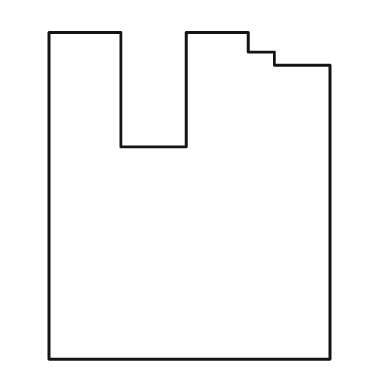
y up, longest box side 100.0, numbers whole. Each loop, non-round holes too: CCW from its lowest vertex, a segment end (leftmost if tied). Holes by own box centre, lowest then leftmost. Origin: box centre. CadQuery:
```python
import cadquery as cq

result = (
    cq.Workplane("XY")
    .moveTo(-43.0, -50.0)
    .lineTo(43.0, -50.0)
    .lineTo(43.0, 40.0)
    .lineTo(26.0, 40.0)
    .lineTo(26.0, 44.0)
    .lineTo(18.0, 44.0)
    .lineTo(18.0, 50.0)
    .lineTo(-1.0, 50.0)
    .lineTo(-1.0, 15.0)
    .lineTo(-21.0, 15.0)
    .lineTo(-21.0, 50.0)
    .lineTo(-43.0, 50.0)
    .close()
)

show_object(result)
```